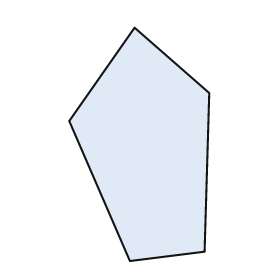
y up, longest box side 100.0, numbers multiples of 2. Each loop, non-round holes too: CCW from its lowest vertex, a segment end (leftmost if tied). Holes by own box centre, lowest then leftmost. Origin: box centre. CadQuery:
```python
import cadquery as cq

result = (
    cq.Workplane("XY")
    .moveTo(-4.0, -50.0)
    .lineTo(28.0, -46.0)
    .lineTo(30.0, 22.0)
    .lineTo(-2.0, 50.0)
    .lineTo(-30.0, 10.0)
    .close()
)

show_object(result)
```